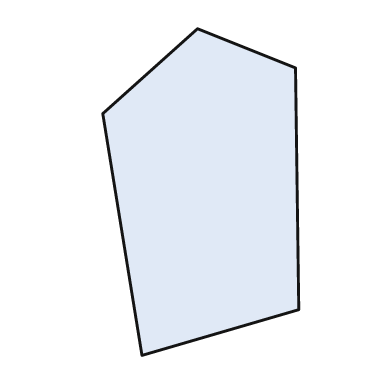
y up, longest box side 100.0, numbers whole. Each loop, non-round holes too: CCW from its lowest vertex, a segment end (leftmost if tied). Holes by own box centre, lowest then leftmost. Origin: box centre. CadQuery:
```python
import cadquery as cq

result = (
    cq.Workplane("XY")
    .moveTo(-18.0, -50.0)
    .lineTo(30.0, -36.0)
    .lineTo(29.0, 38.0)
    .lineTo(-1.0, 50.0)
    .lineTo(-30.0, 24.0)
    .close()
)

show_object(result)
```